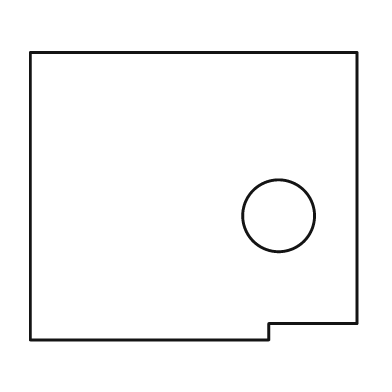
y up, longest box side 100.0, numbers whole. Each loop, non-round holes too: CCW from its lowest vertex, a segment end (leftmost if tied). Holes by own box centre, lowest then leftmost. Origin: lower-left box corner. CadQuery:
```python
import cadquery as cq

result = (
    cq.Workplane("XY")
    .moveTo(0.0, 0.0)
    .lineTo(73.0, 0.0)
    .lineTo(73.0, 5.0)
    .lineTo(100.0, 5.0)
    .lineTo(100.0, 88.0)
    .lineTo(0.0, 88.0)
    .close()
    .moveTo(76.0, 38.0)
    .circle(11.0)
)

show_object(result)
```